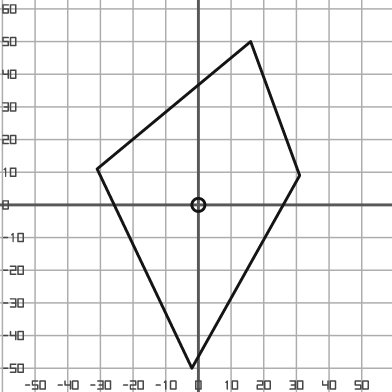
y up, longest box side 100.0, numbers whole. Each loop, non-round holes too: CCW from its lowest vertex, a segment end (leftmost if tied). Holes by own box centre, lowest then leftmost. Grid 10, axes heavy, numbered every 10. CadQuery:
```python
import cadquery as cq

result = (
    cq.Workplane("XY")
    .moveTo(-2.0, -50.0)
    .lineTo(31.0, 9.0)
    .lineTo(16.0, 50.0)
    .lineTo(-31.0, 11.0)
    .close()
    .moveTo(0.0, 0.0)
    .circle(2.0)
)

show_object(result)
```